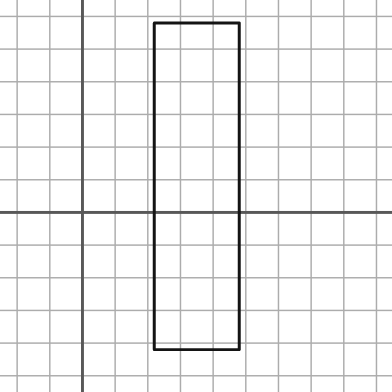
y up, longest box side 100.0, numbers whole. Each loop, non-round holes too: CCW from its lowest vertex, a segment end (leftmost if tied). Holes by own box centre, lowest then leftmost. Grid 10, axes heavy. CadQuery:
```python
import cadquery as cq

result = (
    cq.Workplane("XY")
    .moveTo(22.0, -42.0)
    .lineTo(48.0, -42.0)
    .lineTo(48.0, 58.0)
    .lineTo(22.0, 58.0)
    .close()
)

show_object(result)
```